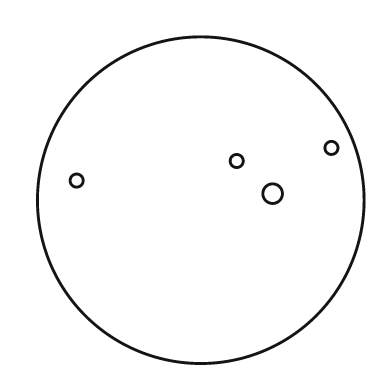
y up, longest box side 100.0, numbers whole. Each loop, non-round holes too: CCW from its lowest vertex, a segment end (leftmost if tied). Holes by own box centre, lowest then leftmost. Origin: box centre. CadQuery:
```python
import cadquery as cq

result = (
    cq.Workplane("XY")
    .moveTo(0.0, 0.0)
    .circle(50.0)
    .moveTo(22.0, 2.0)
    .circle(3.0)
    .moveTo(-38.0, 6.0)
    .circle(2.0)
    .moveTo(11.0, 12.0)
    .circle(2.0)
    .moveTo(40.0, 16.0)
    .circle(2.0)
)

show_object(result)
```